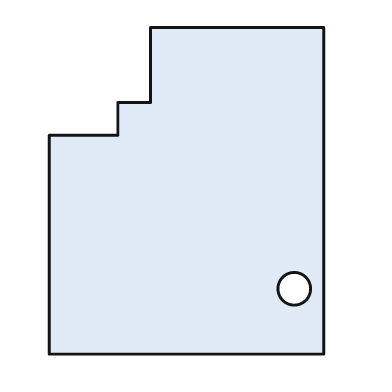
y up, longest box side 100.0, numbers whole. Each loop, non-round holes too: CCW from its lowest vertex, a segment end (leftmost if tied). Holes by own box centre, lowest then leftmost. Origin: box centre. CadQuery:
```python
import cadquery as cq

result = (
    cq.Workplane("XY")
    .moveTo(-42.0, -50.0)
    .lineTo(42.0, -50.0)
    .lineTo(42.0, 50.0)
    .lineTo(-11.0, 50.0)
    .lineTo(-11.0, 27.0)
    .lineTo(-21.0, 27.0)
    .lineTo(-21.0, 17.0)
    .lineTo(-42.0, 17.0)
    .close()
    .moveTo(33.0, -30.0)
    .circle(5.0)
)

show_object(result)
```